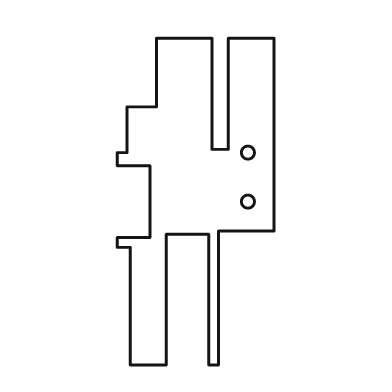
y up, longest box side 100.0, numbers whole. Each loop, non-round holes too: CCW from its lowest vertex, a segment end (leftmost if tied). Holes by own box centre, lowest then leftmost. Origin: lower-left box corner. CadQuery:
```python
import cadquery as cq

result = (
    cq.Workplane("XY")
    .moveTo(4.0, 0.0)
    .lineTo(15.0, 0.0)
    .lineTo(15.0, 40.0)
    .lineTo(28.0, 40.0)
    .lineTo(28.0, 0.0)
    .lineTo(31.0, 0.0)
    .lineTo(31.0, 41.0)
    .lineTo(48.0, 41.0)
    .lineTo(48.0, 100.0)
    .lineTo(34.0, 100.0)
    .lineTo(34.0, 66.0)
    .lineTo(29.0, 66.0)
    .lineTo(29.0, 100.0)
    .lineTo(12.0, 100.0)
    .lineTo(12.0, 79.0)
    .lineTo(3.0, 79.0)
    .lineTo(3.0, 65.0)
    .lineTo(0.0, 65.0)
    .lineTo(0.0, 61.0)
    .lineTo(10.0, 61.0)
    .lineTo(10.0, 39.0)
    .lineTo(0.0, 39.0)
    .lineTo(0.0, 36.0)
    .lineTo(4.0, 36.0)
    .close()
    .moveTo(40.0, 50.0)
    .circle(2.0)
    .moveTo(40.0, 65.0)
    .circle(2.0)
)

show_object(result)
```